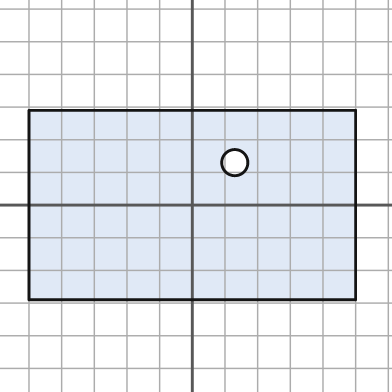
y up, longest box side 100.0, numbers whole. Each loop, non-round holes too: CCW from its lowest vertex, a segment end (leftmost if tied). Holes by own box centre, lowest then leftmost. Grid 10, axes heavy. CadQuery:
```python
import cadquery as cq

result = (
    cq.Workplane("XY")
    .moveTo(-50.0, -29.0)
    .lineTo(50.0, -29.0)
    .lineTo(50.0, 29.0)
    .lineTo(-50.0, 29.0)
    .close()
    .moveTo(13.0, 13.0)
    .circle(4.0)
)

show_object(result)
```